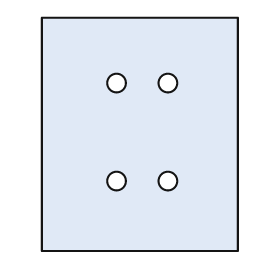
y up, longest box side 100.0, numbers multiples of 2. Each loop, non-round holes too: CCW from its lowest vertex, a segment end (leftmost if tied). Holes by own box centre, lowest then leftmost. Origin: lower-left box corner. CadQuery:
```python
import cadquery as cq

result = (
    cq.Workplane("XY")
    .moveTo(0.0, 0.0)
    .lineTo(84.0, 0.0)
    .lineTo(84.0, 100.0)
    .lineTo(0.0, 100.0)
    .close()
    .moveTo(32.0, 30.0)
    .circle(4.0)
    .moveTo(54.0, 30.0)
    .circle(4.0)
    .moveTo(32.0, 72.0)
    .circle(4.0)
    .moveTo(54.0, 72.0)
    .circle(4.0)
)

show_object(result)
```